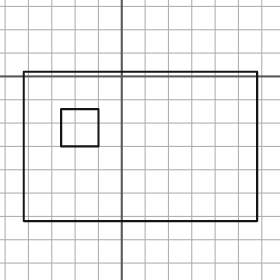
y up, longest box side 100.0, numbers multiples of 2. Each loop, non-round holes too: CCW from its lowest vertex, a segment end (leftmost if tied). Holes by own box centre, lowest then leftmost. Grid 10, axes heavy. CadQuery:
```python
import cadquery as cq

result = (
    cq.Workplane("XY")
    .moveTo(-42.0, -62.0)
    .lineTo(58.0, -62.0)
    .lineTo(58.0, 2.0)
    .lineTo(-42.0, 2.0)
    .close()
    .moveTo(-26.0, -30.0)
    .lineTo(-10.0, -30.0)
    .lineTo(-10.0, -14.0)
    .lineTo(-26.0, -14.0)
    .close()
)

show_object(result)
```